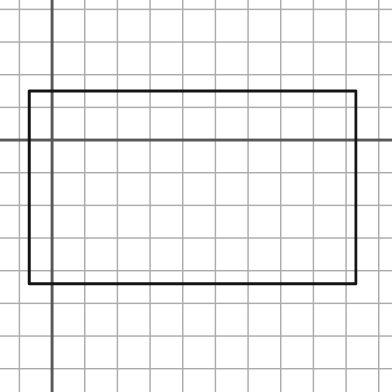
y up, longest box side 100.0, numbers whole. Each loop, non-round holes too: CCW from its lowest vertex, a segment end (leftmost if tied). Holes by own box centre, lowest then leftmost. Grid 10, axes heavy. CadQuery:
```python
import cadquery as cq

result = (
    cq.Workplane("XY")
    .moveTo(-7.0, -44.0)
    .lineTo(93.0, -44.0)
    .lineTo(93.0, 15.0)
    .lineTo(-7.0, 15.0)
    .close()
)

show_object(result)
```